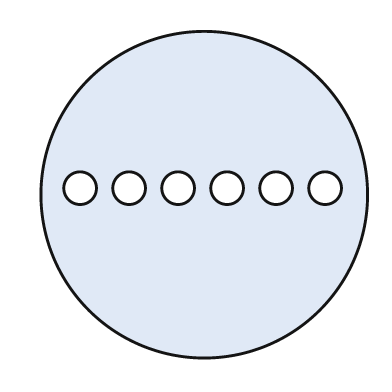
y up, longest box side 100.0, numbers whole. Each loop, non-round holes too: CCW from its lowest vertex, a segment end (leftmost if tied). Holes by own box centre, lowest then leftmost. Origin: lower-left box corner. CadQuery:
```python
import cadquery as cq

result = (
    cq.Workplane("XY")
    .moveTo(50.0, 50.0)
    .circle(50.0)
    .moveTo(12.0, 52.0)
    .circle(5.0)
    .moveTo(27.0, 52.0)
    .circle(5.0)
    .moveTo(42.0, 52.0)
    .circle(5.0)
    .moveTo(57.0, 52.0)
    .circle(5.0)
    .moveTo(72.0, 52.0)
    .circle(5.0)
    .moveTo(87.0, 52.0)
    .circle(5.0)
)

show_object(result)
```